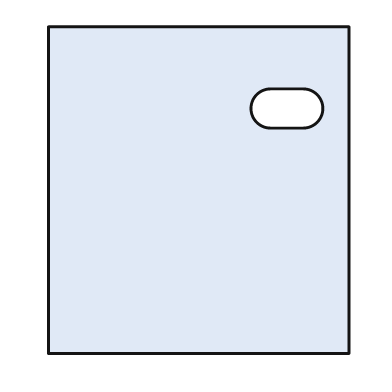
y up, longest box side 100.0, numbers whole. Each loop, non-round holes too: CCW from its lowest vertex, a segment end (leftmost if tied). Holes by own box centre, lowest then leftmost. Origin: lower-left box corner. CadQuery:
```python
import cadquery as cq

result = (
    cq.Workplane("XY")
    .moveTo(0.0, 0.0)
    .lineTo(92.0, 0.0)
    .lineTo(92.0, 100.0)
    .lineTo(0.0, 100.0)
    .close()
    .moveTo(68.0, 69.0)
    .lineTo(78.0, 69.0)
    .threePointArc((84.0, 75.0), (78.0, 81.0))
    .lineTo(68.0, 81.0)
    .threePointArc((62.0, 75.0), (68.0, 69.0))
    .close()
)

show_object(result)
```